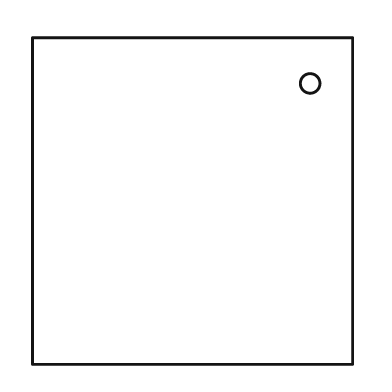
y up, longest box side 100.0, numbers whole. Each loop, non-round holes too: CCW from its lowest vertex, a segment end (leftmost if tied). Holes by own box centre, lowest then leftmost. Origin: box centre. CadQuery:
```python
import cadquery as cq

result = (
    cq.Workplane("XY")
    .moveTo(-49.0, -50.0)
    .lineTo(49.0, -50.0)
    .lineTo(49.0, 50.0)
    .lineTo(-49.0, 50.0)
    .close()
    .moveTo(36.0, 36.0)
    .circle(3.0)
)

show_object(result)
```